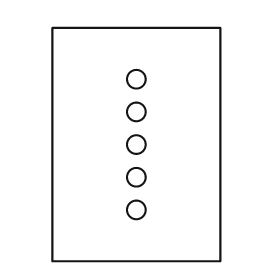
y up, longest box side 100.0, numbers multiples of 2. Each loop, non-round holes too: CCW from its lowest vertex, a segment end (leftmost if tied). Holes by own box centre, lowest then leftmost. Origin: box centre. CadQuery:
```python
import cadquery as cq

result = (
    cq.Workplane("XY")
    .moveTo(-36.0, -50.0)
    .lineTo(36.0, -50.0)
    .lineTo(36.0, 50.0)
    .lineTo(-36.0, 50.0)
    .close()
    .moveTo(0.0, -28.0)
    .circle(4.0)
    .moveTo(0.0, -14.0)
    .circle(4.0)
    .moveTo(0.0, 0.0)
    .circle(4.0)
    .moveTo(0.0, 14.0)
    .circle(4.0)
    .moveTo(0.0, 28.0)
    .circle(4.0)
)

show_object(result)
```